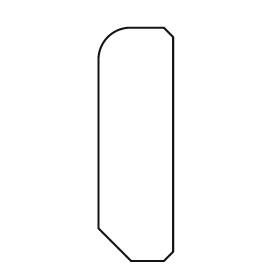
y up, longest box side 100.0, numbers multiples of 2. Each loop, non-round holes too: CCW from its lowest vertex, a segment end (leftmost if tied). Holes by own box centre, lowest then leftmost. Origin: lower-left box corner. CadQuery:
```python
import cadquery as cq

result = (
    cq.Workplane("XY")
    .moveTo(14.0, 0.0)
    .lineTo(28.0, 0.0)
    .lineTo(32.0, 4.0)
    .lineTo(32.0, 96.0)
    .lineTo(28.0, 100.0)
    .lineTo(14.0, 100.0)
    .threePointArc((4.0, 96.0), (0.0, 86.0))
    .lineTo(0.0, 14.0)
    .close()
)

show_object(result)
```